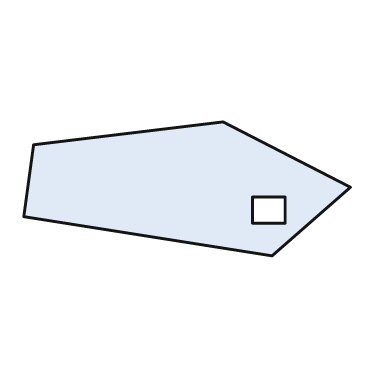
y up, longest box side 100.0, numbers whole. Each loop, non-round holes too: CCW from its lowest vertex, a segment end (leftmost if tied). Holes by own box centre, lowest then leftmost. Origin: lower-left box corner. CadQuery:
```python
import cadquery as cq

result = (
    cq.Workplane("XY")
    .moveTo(76.0, 0.0)
    .lineTo(100.0, 21.0)
    .lineTo(61.0, 41.0)
    .lineTo(3.0, 34.0)
    .lineTo(0.0, 12.0)
    .close()
    .moveTo(70.0, 10.0)
    .lineTo(80.0, 10.0)
    .lineTo(80.0, 18.0)
    .lineTo(70.0, 18.0)
    .close()
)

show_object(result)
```